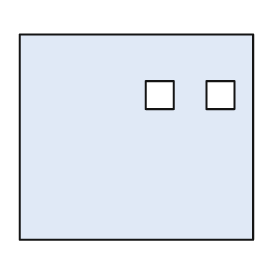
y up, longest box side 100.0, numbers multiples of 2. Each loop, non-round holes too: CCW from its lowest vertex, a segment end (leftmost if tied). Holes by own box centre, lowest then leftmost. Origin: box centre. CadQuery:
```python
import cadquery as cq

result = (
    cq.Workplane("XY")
    .moveTo(-50.0, -44.0)
    .lineTo(50.0, -44.0)
    .lineTo(50.0, 44.0)
    .lineTo(-50.0, 44.0)
    .close()
    .moveTo(4.0, 12.0)
    .lineTo(16.0, 12.0)
    .lineTo(16.0, 24.0)
    .lineTo(4.0, 24.0)
    .close()
    .moveTo(30.0, 12.0)
    .lineTo(42.0, 12.0)
    .lineTo(42.0, 24.0)
    .lineTo(30.0, 24.0)
    .close()
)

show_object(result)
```